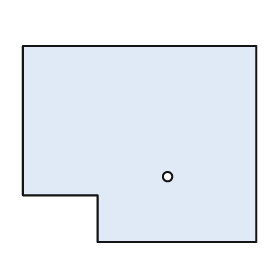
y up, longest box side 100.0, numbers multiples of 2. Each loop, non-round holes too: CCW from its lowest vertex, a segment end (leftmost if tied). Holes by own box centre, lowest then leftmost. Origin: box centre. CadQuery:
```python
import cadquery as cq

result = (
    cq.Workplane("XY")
    .moveTo(-18.0, -42.0)
    .lineTo(50.0, -42.0)
    .lineTo(50.0, 42.0)
    .lineTo(-50.0, 42.0)
    .lineTo(-50.0, -22.0)
    .lineTo(-18.0, -22.0)
    .close()
    .moveTo(12.0, -14.0)
    .circle(2.0)
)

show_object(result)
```